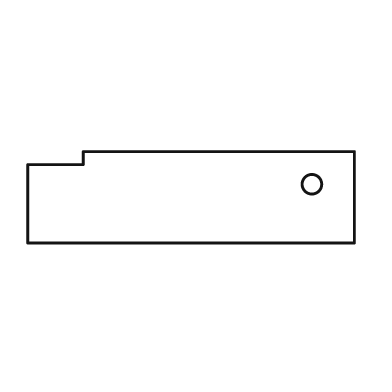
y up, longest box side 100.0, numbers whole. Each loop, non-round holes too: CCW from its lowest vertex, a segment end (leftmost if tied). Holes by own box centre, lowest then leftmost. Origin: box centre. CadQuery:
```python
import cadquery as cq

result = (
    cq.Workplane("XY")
    .moveTo(-50.0, -14.0)
    .lineTo(50.0, -14.0)
    .lineTo(50.0, 14.0)
    .lineTo(-33.0, 14.0)
    .lineTo(-33.0, 10.0)
    .lineTo(-50.0, 10.0)
    .close()
    .moveTo(37.0, 4.0)
    .circle(3.0)
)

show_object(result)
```